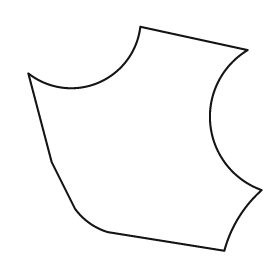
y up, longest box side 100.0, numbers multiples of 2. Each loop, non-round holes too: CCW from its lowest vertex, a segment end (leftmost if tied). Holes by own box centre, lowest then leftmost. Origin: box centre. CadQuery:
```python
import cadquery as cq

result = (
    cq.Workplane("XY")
    .moveTo(34.0, -48.0)
    .threePointArc((40.0, -34.0), (50.0, -22.0))
    .threePointArc((28.0, 6.0), (44.0, 38.0))
    .lineTo(-2.0, 48.0)
    .threePointArc((-20.0, 24.0), (-50.0, 28.0))
    .lineTo(-40.0, -10.0)
    .lineTo(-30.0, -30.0)
    .threePointArc((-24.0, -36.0), (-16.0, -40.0))
    .close()
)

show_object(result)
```